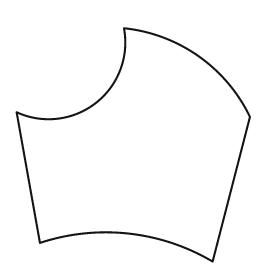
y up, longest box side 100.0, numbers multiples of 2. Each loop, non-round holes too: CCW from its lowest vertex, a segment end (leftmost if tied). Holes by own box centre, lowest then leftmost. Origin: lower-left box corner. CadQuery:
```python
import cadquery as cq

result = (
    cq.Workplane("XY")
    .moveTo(84.0, 0.0)
    .lineTo(100.0, 62.0)
    .threePointArc((78.0, 88.0), (46.0, 100.0))
    .threePointArc((34.0, 68.0), (0.0, 64.0))
    .lineTo(10.0, 8.0)
    .threePointArc((48.0, 12.0), (84.0, 0.0))
    .close()
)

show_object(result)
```